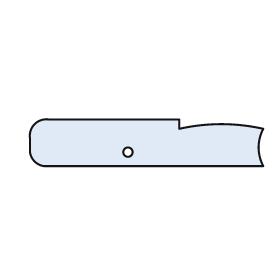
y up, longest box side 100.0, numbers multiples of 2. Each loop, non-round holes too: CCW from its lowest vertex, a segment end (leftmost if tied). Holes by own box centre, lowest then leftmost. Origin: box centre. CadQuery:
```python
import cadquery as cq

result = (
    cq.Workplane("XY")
    .moveTo(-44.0, -10.0)
    .lineTo(50.0, -10.0)
    .threePointArc((48.0, -2.0), (50.0, 6.0))
    .threePointArc((32.0, 8.0), (14.0, 6.0))
    .lineTo(14.0, 10.0)
    .lineTo(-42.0, 10.0)
    .threePointArc((-48.0, 8.0), (-50.0, 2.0))
    .lineTo(-50.0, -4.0)
    .threePointArc((-48.0, -8.0), (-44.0, -10.0))
    .close()
    .moveTo(-8.0, -4.0)
    .circle(2.0)
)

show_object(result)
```